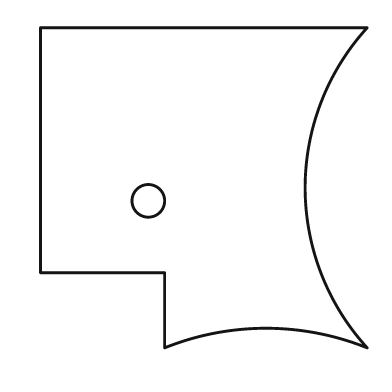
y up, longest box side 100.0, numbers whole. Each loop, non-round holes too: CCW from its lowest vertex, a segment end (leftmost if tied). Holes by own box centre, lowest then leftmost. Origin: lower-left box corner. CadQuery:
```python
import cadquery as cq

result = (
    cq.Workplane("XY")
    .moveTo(38.0, 0.0)
    .threePointArc((69.0, 6.0), (100.0, 0.0))
    .threePointArc((81.0, 49.0), (100.0, 98.0))
    .lineTo(0.0, 98.0)
    .lineTo(0.0, 23.0)
    .lineTo(38.0, 23.0)
    .close()
    .moveTo(33.0, 45.0)
    .circle(5.0)
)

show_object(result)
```